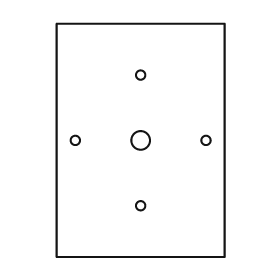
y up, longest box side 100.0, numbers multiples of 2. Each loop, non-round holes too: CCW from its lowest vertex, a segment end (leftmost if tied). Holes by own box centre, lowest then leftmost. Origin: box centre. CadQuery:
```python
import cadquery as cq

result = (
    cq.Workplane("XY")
    .moveTo(-36.0, -50.0)
    .lineTo(36.0, -50.0)
    .lineTo(36.0, 50.0)
    .lineTo(-36.0, 50.0)
    .close()
    .moveTo(0.0, -28.0)
    .circle(2.0)
    .moveTo(-28.0, 0.0)
    .circle(2.0)
    .moveTo(0.0, 0.0)
    .circle(4.0)
    .moveTo(28.0, 0.0)
    .circle(2.0)
    .moveTo(0.0, 28.0)
    .circle(2.0)
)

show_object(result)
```